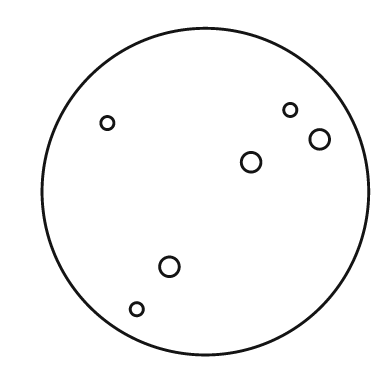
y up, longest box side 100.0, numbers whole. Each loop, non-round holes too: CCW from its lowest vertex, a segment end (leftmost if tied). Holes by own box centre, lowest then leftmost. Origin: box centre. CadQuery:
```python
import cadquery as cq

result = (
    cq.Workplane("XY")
    .moveTo(0.0, 0.0)
    .circle(50.0)
    .moveTo(-21.0, -36.0)
    .circle(2.0)
    .moveTo(-11.0, -23.0)
    .circle(3.0)
    .moveTo(14.0, 9.0)
    .circle(3.0)
    .moveTo(35.0, 16.0)
    .circle(3.0)
    .moveTo(-30.0, 21.0)
    .circle(2.0)
    .moveTo(26.0, 25.0)
    .circle(2.0)
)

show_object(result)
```